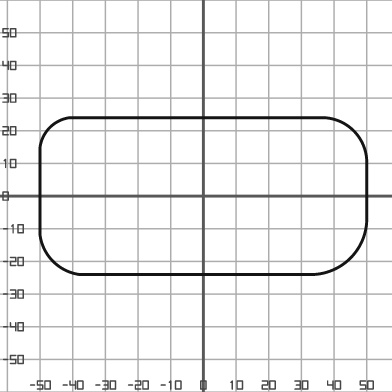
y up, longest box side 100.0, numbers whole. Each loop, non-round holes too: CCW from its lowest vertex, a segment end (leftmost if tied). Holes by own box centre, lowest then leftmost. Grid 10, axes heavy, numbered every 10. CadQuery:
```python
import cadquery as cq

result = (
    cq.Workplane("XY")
    .moveTo(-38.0, -24.0)
    .lineTo(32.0, -24.0)
    .threePointArc((45.0, -19.0), (50.0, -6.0))
    .lineTo(50.0, 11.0)
    .threePointArc((46.0, 20.0), (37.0, 24.0))
    .lineTo(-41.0, 24.0)
    .threePointArc((-47.0, 21.0), (-50.0, 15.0))
    .lineTo(-50.0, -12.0)
    .threePointArc((-46.0, -20.0), (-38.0, -24.0))
    .close()
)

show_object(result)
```